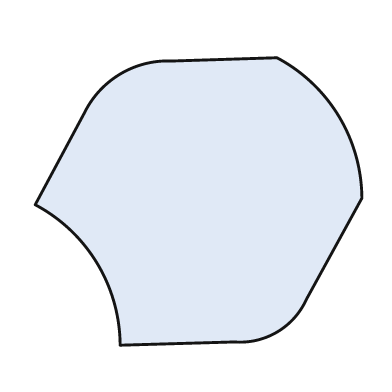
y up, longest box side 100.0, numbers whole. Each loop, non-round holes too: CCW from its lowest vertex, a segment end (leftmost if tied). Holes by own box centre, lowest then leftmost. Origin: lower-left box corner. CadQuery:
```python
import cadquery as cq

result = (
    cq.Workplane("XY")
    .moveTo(26.0, 0.0)
    .lineTo(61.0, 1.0)
    .threePointArc((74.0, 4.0), (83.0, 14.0))
    .lineTo(100.0, 45.0)
    .threePointArc((93.0, 70.0), (74.0, 88.0))
    .lineTo(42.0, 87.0)
    .threePointArc((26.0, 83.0), (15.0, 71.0))
    .lineTo(0.0, 43.0)
    .threePointArc((19.0, 25.0), (26.0, 0.0))
    .close()
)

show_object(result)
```